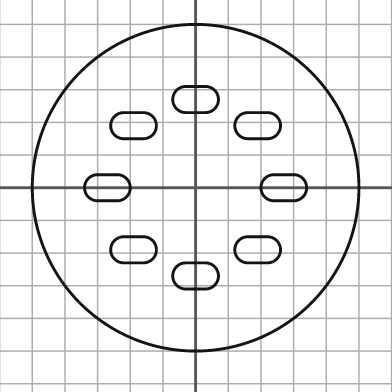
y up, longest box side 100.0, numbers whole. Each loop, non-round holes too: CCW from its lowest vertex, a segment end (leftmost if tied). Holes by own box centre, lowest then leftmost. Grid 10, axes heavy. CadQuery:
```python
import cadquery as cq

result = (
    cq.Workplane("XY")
    .moveTo(0.0, 0.0)
    .circle(50.0)
    .moveTo(-3.0, -31.0)
    .lineTo(3.0, -31.0)
    .threePointArc((7.0, -27.0), (3.0, -23.0))
    .lineTo(-3.0, -23.0)
    .threePointArc((-7.0, -27.0), (-3.0, -31.0))
    .close()
    .moveTo(-22.0, -23.0)
    .lineTo(-16.0, -23.0)
    .threePointArc((-12.0, -19.0), (-16.0, -15.0))
    .lineTo(-22.0, -15.0)
    .threePointArc((-26.0, -19.0), (-22.0, -23.0))
    .close()
    .moveTo(16.0, -23.0)
    .lineTo(22.0, -23.0)
    .threePointArc((26.0, -19.0), (22.0, -15.0))
    .lineTo(16.0, -15.0)
    .threePointArc((12.0, -19.0), (16.0, -23.0))
    .close()
    .moveTo(-30.0, -4.0)
    .lineTo(-24.0, -4.0)
    .threePointArc((-20.0, 0.0), (-24.0, 4.0))
    .lineTo(-30.0, 4.0)
    .threePointArc((-34.0, 0.0), (-30.0, -4.0))
    .close()
    .moveTo(24.0, -4.0)
    .lineTo(30.0, -4.0)
    .threePointArc((34.0, 0.0), (30.0, 4.0))
    .lineTo(24.0, 4.0)
    .threePointArc((20.0, 0.0), (24.0, -4.0))
    .close()
    .moveTo(-22.0, 15.0)
    .lineTo(-16.0, 15.0)
    .threePointArc((-12.0, 19.0), (-16.0, 23.0))
    .lineTo(-22.0, 23.0)
    .threePointArc((-26.0, 19.0), (-22.0, 15.0))
    .close()
    .moveTo(16.0, 15.0)
    .lineTo(22.0, 15.0)
    .threePointArc((26.0, 19.0), (22.0, 23.0))
    .lineTo(16.0, 23.0)
    .threePointArc((12.0, 19.0), (16.0, 15.0))
    .close()
    .moveTo(-3.0, 23.0)
    .lineTo(3.0, 23.0)
    .threePointArc((7.0, 27.0), (3.0, 31.0))
    .lineTo(-3.0, 31.0)
    .threePointArc((-7.0, 27.0), (-3.0, 23.0))
    .close()
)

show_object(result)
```